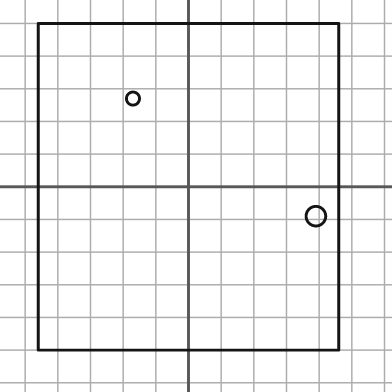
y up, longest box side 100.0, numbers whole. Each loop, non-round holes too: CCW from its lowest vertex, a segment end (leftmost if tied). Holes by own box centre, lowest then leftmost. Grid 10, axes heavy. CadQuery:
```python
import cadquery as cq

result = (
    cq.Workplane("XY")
    .moveTo(-46.0, -50.0)
    .lineTo(46.0, -50.0)
    .lineTo(46.0, 50.0)
    .lineTo(-46.0, 50.0)
    .close()
    .moveTo(39.0, -9.0)
    .circle(3.0)
    .moveTo(-17.0, 27.0)
    .circle(2.0)
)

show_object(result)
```